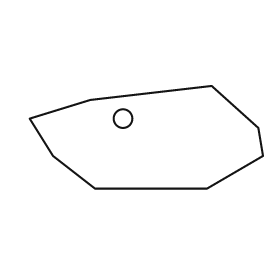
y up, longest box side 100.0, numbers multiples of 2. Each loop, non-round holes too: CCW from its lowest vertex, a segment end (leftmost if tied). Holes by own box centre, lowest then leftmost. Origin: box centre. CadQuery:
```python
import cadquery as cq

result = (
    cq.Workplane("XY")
    .moveTo(-22.0, -22.0)
    .lineTo(26.0, -22.0)
    .lineTo(50.0, -8.0)
    .lineTo(48.0, 4.0)
    .lineTo(28.0, 22.0)
    .lineTo(-24.0, 16.0)
    .lineTo(-50.0, 8.0)
    .lineTo(-40.0, -8.0)
    .close()
    .moveTo(-10.0, 8.0)
    .circle(4.0)
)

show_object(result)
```